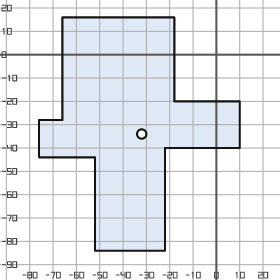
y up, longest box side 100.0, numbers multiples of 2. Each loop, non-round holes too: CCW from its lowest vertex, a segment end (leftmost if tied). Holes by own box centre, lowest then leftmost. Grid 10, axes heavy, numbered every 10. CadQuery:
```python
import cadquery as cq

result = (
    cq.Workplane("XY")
    .moveTo(-52.0, -84.0)
    .lineTo(-22.0, -84.0)
    .lineTo(-22.0, -40.0)
    .lineTo(10.0, -40.0)
    .lineTo(10.0, -20.0)
    .lineTo(-18.0, -20.0)
    .lineTo(-18.0, 16.0)
    .lineTo(-66.0, 16.0)
    .lineTo(-66.0, -28.0)
    .lineTo(-76.0, -28.0)
    .lineTo(-76.0, -44.0)
    .lineTo(-52.0, -44.0)
    .close()
    .moveTo(-32.0, -34.0)
    .circle(2.0)
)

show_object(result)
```